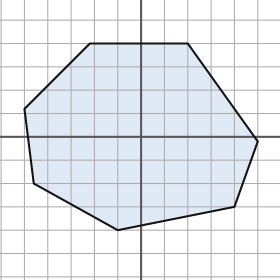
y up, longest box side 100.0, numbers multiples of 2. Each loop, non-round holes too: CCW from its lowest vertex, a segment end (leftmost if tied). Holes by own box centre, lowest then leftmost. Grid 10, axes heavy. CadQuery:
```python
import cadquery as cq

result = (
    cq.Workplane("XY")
    .moveTo(-10.0, -40.0)
    .lineTo(40.0, -30.0)
    .lineTo(50.0, -2.0)
    .lineTo(20.0, 40.0)
    .lineTo(-22.0, 40.0)
    .lineTo(-50.0, 12.0)
    .lineTo(-46.0, -20.0)
    .close()
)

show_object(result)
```